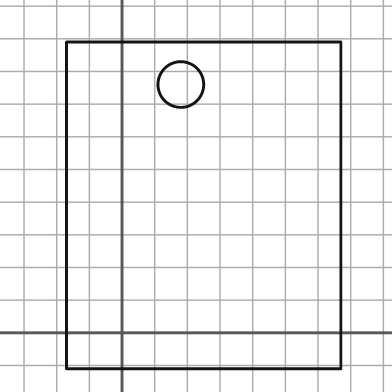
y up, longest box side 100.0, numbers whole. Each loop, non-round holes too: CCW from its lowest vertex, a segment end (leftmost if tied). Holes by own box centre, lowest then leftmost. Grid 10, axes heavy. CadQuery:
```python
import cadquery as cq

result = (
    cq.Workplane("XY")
    .moveTo(-17.0, -11.0)
    .lineTo(67.0, -11.0)
    .lineTo(67.0, 89.0)
    .lineTo(-17.0, 89.0)
    .close()
    .moveTo(18.0, 76.0)
    .circle(7.0)
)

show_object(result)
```